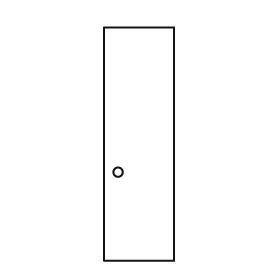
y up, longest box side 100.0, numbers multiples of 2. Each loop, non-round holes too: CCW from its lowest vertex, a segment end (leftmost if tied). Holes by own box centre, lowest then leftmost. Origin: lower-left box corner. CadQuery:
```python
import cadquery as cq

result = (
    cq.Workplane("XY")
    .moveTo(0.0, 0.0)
    .lineTo(30.0, 0.0)
    .lineTo(30.0, 100.0)
    .lineTo(0.0, 100.0)
    .close()
    .moveTo(6.0, 38.0)
    .circle(2.0)
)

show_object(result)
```